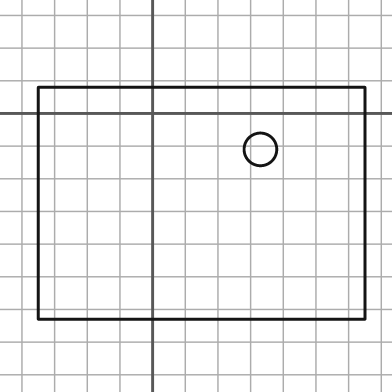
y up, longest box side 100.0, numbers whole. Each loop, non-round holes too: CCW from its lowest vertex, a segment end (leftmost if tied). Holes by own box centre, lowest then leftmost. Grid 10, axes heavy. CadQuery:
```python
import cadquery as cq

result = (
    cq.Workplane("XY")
    .moveTo(-35.0, -63.0)
    .lineTo(65.0, -63.0)
    .lineTo(65.0, 8.0)
    .lineTo(-35.0, 8.0)
    .close()
    .moveTo(33.0, -11.0)
    .circle(5.0)
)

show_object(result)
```